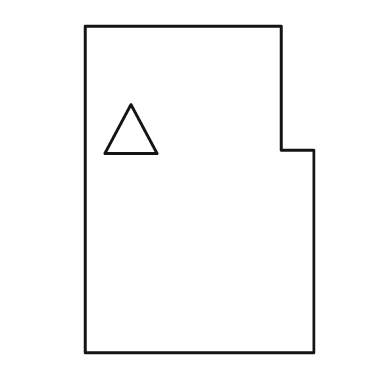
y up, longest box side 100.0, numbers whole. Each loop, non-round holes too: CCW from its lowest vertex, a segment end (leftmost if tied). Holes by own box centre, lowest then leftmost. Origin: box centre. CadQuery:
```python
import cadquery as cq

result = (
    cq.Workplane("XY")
    .moveTo(-35.0, -50.0)
    .lineTo(35.0, -50.0)
    .lineTo(35.0, 12.0)
    .lineTo(25.0, 12.0)
    .lineTo(25.0, 50.0)
    .lineTo(-35.0, 50.0)
    .close()
    .moveTo(-29.0, 11.0)
    .lineTo(-13.0, 11.0)
    .lineTo(-21.0, 26.0)
    .close()
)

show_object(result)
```